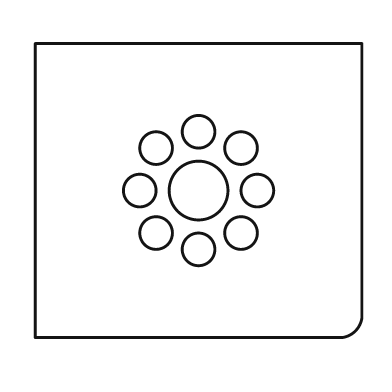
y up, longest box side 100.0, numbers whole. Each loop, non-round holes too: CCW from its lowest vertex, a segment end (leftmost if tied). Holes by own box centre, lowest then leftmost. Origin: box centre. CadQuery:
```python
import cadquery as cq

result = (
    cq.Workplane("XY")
    .moveTo(-50.0, -45.0)
    .lineTo(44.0, -45.0)
    .threePointArc((48.0, -43.0), (50.0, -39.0))
    .lineTo(50.0, 45.0)
    .lineTo(-50.0, 45.0)
    .close()
    .moveTo(0.0, -18.0)
    .circle(5.0)
    .moveTo(-13.0, -13.0)
    .circle(5.0)
    .moveTo(13.0, -13.0)
    .circle(5.0)
    .moveTo(-18.0, 0.0)
    .circle(5.0)
    .moveTo(0.0, 0.0)
    .circle(9.0)
    .moveTo(18.0, 0.0)
    .circle(5.0)
    .moveTo(-13.0, 13.0)
    .circle(5.0)
    .moveTo(13.0, 13.0)
    .circle(5.0)
    .moveTo(0.0, 18.0)
    .circle(5.0)
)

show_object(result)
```